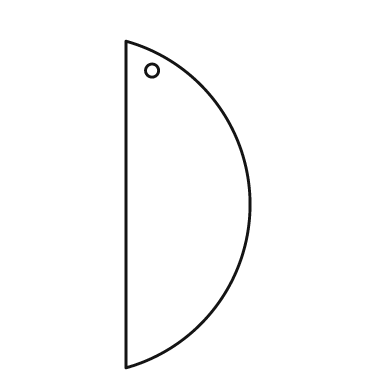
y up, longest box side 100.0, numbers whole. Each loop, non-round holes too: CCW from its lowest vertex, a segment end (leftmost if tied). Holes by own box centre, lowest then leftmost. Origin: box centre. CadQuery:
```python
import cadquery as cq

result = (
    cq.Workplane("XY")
    .moveTo(-19.0, -50.0)
    .threePointArc((19.0, 0.0), (-19.0, 50.0))
    .close()
    .moveTo(-11.0, 41.0)
    .circle(2.0)
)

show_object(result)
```